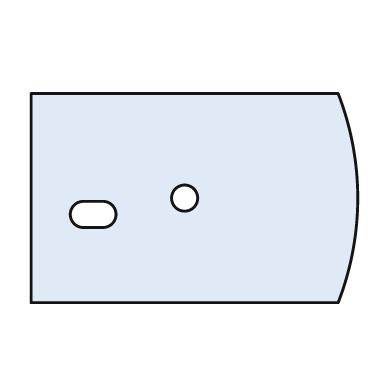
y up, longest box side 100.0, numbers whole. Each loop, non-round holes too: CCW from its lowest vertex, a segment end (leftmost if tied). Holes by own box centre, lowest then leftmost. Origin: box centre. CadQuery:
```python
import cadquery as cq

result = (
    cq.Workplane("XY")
    .moveTo(-50.0, -32.0)
    .lineTo(44.0, -32.0)
    .threePointArc((50.0, 0.0), (44.0, 32.0))
    .lineTo(-50.0, 32.0)
    .close()
    .moveTo(-34.0, -9.0)
    .lineTo(-28.0, -9.0)
    .threePointArc((-24.0, -5.0), (-28.0, -1.0))
    .lineTo(-34.0, -1.0)
    .threePointArc((-38.0, -5.0), (-34.0, -9.0))
    .close()
    .moveTo(-3.0, 0.0)
    .circle(4.0)
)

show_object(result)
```